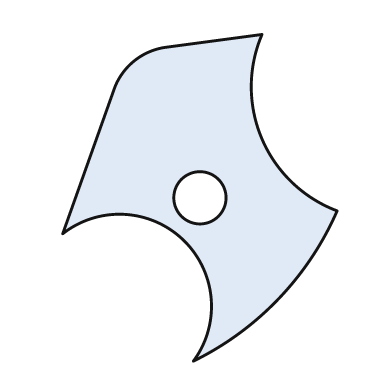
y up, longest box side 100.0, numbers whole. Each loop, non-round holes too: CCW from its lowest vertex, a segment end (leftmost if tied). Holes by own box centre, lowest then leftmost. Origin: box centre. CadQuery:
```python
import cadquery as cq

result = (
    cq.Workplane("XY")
    .moveTo(-2.0, -50.0)
    .threePointArc((24.0, -31.0), (42.0, -4.0))
    .threePointArc((19.0, 18.0), (19.0, 50.0))
    .lineTo(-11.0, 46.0)
    .threePointArc((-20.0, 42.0), (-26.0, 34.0))
    .lineTo(-42.0, -11.0)
    .threePointArc((-5.0, -13.0), (-2.0, -50.0))
    .close()
    .moveTo(0.0, 0.0)
    .circle(8.0)
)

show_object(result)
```